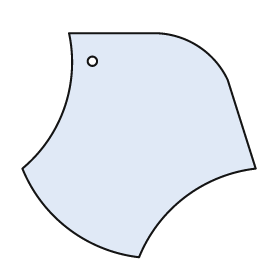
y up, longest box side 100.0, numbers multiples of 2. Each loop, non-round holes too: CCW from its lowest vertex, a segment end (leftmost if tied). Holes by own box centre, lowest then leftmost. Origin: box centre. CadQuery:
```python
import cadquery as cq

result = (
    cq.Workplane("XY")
    .moveTo(0.0, -48.0)
    .threePointArc((20.0, -22.0), (50.0, -10.0))
    .lineTo(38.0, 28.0)
    .threePointArc((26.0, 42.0), (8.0, 48.0))
    .lineTo(-30.0, 48.0)
    .threePointArc((-32.0, 16.0), (-50.0, -10.0))
    .threePointArc((-30.0, -36.0), (0.0, -48.0))
    .close()
    .moveTo(-20.0, 36.0)
    .circle(2.0)
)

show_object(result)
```